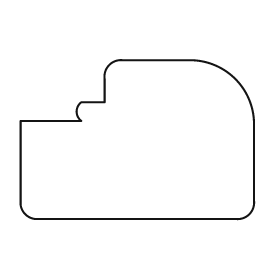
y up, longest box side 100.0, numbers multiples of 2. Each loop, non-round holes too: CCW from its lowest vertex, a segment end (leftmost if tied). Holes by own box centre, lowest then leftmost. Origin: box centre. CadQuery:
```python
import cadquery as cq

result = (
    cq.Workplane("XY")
    .moveTo(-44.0, -34.0)
    .lineTo(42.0, -34.0)
    .threePointArc((48.0, -32.0), (50.0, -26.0))
    .lineTo(50.0, 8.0)
    .threePointArc((42.0, 26.0), (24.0, 34.0))
    .lineTo(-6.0, 34.0)
    .threePointArc((-12.0, 32.0), (-14.0, 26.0))
    .lineTo(-14.0, 16.0)
    .lineTo(-24.0, 16.0)
    .threePointArc((-26.0, 12.0), (-24.0, 8.0))
    .lineTo(-50.0, 8.0)
    .lineTo(-50.0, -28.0)
    .threePointArc((-48.0, -32.0), (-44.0, -34.0))
    .close()
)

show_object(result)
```